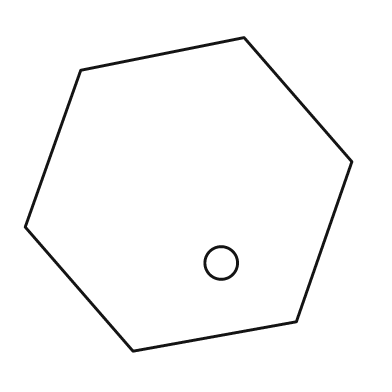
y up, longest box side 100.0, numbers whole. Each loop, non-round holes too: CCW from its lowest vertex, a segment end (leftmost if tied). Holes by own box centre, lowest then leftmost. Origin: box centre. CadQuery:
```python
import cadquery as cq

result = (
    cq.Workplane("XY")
    .moveTo(-17.0, -48.0)
    .lineTo(33.0, -39.0)
    .lineTo(50.0, 10.0)
    .lineTo(17.0, 48.0)
    .lineTo(-33.0, 38.0)
    .lineTo(-50.0, -10.0)
    .close()
    .moveTo(10.0, -21.0)
    .circle(5.0)
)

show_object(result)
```